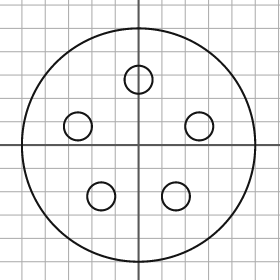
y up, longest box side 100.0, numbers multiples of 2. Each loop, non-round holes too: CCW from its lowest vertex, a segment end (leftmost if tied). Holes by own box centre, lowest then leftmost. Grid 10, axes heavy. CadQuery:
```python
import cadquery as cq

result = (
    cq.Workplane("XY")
    .moveTo(0.0, 0.0)
    .circle(50.0)
    .moveTo(-16.0, -22.0)
    .circle(6.0)
    .moveTo(16.0, -22.0)
    .circle(6.0)
    .moveTo(-26.0, 8.0)
    .circle(6.0)
    .moveTo(26.0, 8.0)
    .circle(6.0)
    .moveTo(0.0, 28.0)
    .circle(6.0)
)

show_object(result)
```